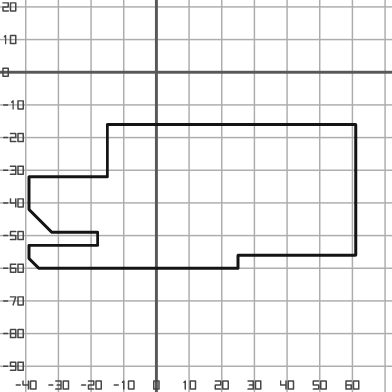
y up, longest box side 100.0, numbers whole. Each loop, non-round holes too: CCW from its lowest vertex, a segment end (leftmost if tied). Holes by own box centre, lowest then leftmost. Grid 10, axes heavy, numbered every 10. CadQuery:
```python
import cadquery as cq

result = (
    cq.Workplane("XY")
    .moveTo(-36.0, -60.0)
    .lineTo(25.0, -60.0)
    .lineTo(25.0, -56.0)
    .lineTo(61.0, -56.0)
    .lineTo(61.0, -16.0)
    .lineTo(-15.0, -16.0)
    .lineTo(-15.0, -32.0)
    .lineTo(-39.0, -32.0)
    .lineTo(-39.0, -42.0)
    .lineTo(-32.0, -49.0)
    .lineTo(-18.0, -49.0)
    .lineTo(-18.0, -53.0)
    .lineTo(-39.0, -53.0)
    .lineTo(-39.0, -57.0)
    .close()
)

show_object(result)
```